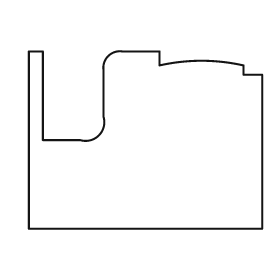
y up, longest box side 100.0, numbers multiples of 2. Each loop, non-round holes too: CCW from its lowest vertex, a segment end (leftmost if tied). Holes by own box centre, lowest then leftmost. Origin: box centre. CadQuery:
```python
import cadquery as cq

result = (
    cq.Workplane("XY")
    .moveTo(-50.0, -38.0)
    .lineTo(50.0, -38.0)
    .lineTo(50.0, 28.0)
    .lineTo(42.0, 28.0)
    .lineTo(42.0, 32.0)
    .threePointArc((24.0, 34.0), (6.0, 32.0))
    .lineTo(6.0, 38.0)
    .lineTo(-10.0, 38.0)
    .threePointArc((-16.0, 36.0), (-18.0, 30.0))
    .lineTo(-18.0, 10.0)
    .threePointArc((-20.0, 2.0), (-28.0, 0.0))
    .lineTo(-44.0, 0.0)
    .lineTo(-44.0, 38.0)
    .lineTo(-50.0, 38.0)
    .close()
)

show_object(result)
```